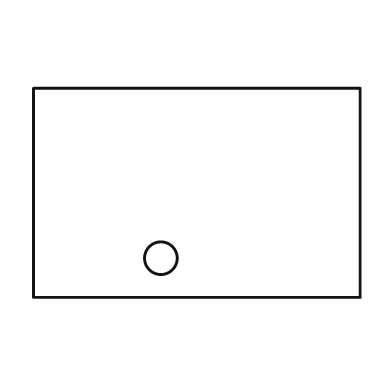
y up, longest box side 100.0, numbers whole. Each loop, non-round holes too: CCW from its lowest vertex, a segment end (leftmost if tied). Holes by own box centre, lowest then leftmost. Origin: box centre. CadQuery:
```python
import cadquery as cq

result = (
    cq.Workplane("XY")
    .moveTo(-50.0, -32.0)
    .lineTo(50.0, -32.0)
    .lineTo(50.0, 32.0)
    .lineTo(-50.0, 32.0)
    .close()
    .moveTo(-11.0, -20.0)
    .circle(5.0)
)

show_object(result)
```